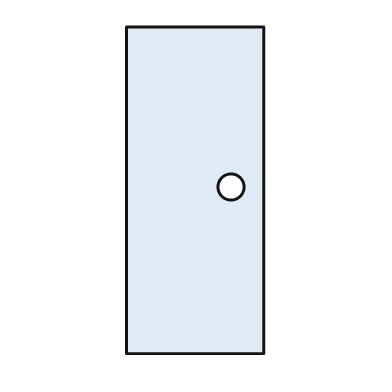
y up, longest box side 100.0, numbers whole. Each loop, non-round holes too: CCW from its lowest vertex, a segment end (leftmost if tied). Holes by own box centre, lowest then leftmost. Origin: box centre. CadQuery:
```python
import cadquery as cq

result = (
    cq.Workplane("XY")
    .moveTo(-21.0, -50.0)
    .lineTo(21.0, -50.0)
    .lineTo(21.0, 50.0)
    .lineTo(-21.0, 50.0)
    .close()
    .moveTo(11.0, 1.0)
    .circle(4.0)
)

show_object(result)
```